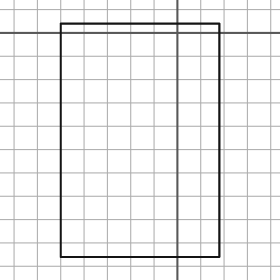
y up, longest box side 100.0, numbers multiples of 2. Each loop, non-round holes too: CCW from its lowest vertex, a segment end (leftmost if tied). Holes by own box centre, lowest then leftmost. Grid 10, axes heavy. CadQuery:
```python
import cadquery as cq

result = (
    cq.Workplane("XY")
    .moveTo(-50.0, -96.0)
    .lineTo(18.0, -96.0)
    .lineTo(18.0, 4.0)
    .lineTo(-50.0, 4.0)
    .close()
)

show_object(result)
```